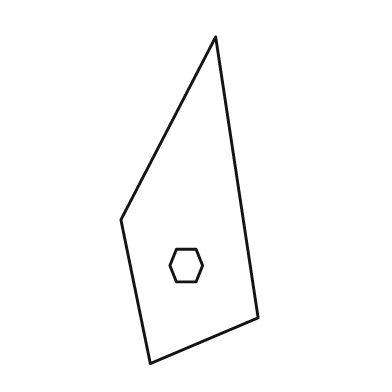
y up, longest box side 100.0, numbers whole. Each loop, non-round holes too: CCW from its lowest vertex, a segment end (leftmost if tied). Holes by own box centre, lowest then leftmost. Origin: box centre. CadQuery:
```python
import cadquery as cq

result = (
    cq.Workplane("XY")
    .moveTo(-12.0, -50.0)
    .lineTo(21.0, -36.0)
    .lineTo(8.0, 50.0)
    .lineTo(-21.0, -6.0)
    .close()
    .moveTo(-4.0, -25.0)
    .lineTo(2.0, -25.0)
    .lineTo(4.0, -20.0)
    .lineTo(2.0, -15.0)
    .lineTo(-4.0, -15.0)
    .lineTo(-6.0, -20.0)
    .close()
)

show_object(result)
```